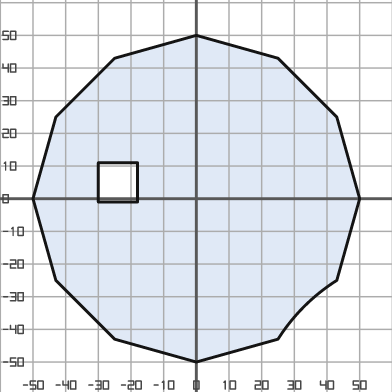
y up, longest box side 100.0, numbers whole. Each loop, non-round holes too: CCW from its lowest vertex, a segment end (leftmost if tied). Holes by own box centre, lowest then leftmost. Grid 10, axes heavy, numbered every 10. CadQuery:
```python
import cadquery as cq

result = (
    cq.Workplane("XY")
    .moveTo(0.0, -50.0)
    .lineTo(25.0, -43.0)
    .threePointArc((33.0, -33.0), (43.0, -25.0))
    .lineTo(50.0, 0.0)
    .lineTo(43.0, 25.0)
    .lineTo(25.0, 43.0)
    .lineTo(0.0, 50.0)
    .lineTo(-25.0, 43.0)
    .lineTo(-43.0, 25.0)
    .lineTo(-50.0, 0.0)
    .lineTo(-43.0, -25.0)
    .lineTo(-25.0, -43.0)
    .close()
    .moveTo(-30.0, -1.0)
    .lineTo(-18.0, -1.0)
    .lineTo(-18.0, 11.0)
    .lineTo(-30.0, 11.0)
    .close()
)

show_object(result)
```